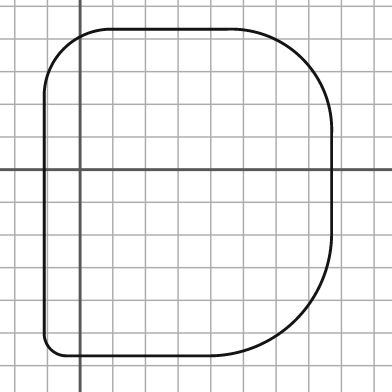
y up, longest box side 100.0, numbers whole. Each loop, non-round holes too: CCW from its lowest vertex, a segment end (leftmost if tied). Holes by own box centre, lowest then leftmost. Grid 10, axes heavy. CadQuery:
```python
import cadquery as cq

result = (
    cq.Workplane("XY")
    .moveTo(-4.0, -57.0)
    .lineTo(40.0, -57.0)
    .threePointArc((66.0, -46.0), (77.0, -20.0))
    .lineTo(77.0, 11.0)
    .threePointArc((68.0, 34.0), (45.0, 43.0))
    .lineTo(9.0, 43.0)
    .threePointArc((-5.0, 37.0), (-11.0, 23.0))
    .lineTo(-11.0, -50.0)
    .threePointArc((-9.0, -55.0), (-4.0, -57.0))
    .close()
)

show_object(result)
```